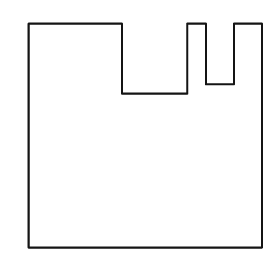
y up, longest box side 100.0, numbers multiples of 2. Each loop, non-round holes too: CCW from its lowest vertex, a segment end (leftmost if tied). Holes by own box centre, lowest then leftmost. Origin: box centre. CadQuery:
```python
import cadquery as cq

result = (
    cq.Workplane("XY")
    .moveTo(-50.0, -48.0)
    .lineTo(50.0, -48.0)
    .lineTo(50.0, 48.0)
    .lineTo(38.0, 48.0)
    .lineTo(38.0, 22.0)
    .lineTo(26.0, 22.0)
    .lineTo(26.0, 48.0)
    .lineTo(18.0, 48.0)
    .lineTo(18.0, 18.0)
    .lineTo(-10.0, 18.0)
    .lineTo(-10.0, 48.0)
    .lineTo(-50.0, 48.0)
    .close()
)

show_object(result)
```